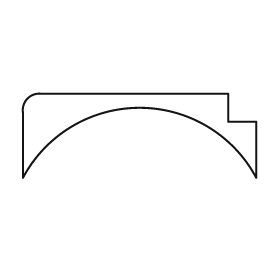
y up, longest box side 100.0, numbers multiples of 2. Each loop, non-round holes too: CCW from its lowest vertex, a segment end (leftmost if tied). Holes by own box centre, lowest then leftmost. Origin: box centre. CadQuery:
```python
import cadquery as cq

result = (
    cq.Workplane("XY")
    .moveTo(-50.0, -18.0)
    .threePointArc((0.0, 12.0), (50.0, -18.0))
    .lineTo(50.0, 6.0)
    .lineTo(38.0, 6.0)
    .lineTo(38.0, 18.0)
    .lineTo(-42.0, 18.0)
    .threePointArc((-48.0, 16.0), (-50.0, 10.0))
    .close()
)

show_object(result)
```